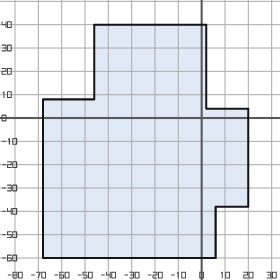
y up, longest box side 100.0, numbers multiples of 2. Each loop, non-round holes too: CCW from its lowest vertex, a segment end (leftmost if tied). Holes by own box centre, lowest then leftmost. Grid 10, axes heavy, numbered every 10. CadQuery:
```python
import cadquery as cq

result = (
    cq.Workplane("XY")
    .moveTo(-68.0, -60.0)
    .lineTo(6.0, -60.0)
    .lineTo(6.0, -38.0)
    .lineTo(20.0, -38.0)
    .lineTo(20.0, 4.0)
    .lineTo(2.0, 4.0)
    .lineTo(2.0, 40.0)
    .lineTo(-46.0, 40.0)
    .lineTo(-46.0, 8.0)
    .lineTo(-68.0, 8.0)
    .close()
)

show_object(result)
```